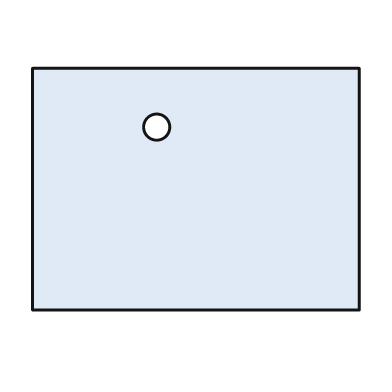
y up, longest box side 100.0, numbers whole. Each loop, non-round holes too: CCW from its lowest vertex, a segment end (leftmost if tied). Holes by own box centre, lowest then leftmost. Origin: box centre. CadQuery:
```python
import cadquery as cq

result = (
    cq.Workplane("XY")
    .moveTo(-50.0, -37.0)
    .lineTo(50.0, -37.0)
    .lineTo(50.0, 37.0)
    .lineTo(-50.0, 37.0)
    .close()
    .moveTo(-12.0, 19.0)
    .circle(4.0)
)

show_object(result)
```